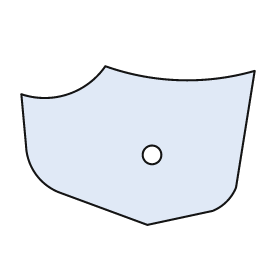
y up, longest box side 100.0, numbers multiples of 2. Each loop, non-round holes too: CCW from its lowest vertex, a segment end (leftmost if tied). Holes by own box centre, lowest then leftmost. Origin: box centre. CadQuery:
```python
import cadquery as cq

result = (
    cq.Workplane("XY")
    .moveTo(4.0, -34.0)
    .lineTo(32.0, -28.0)
    .threePointArc((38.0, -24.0), (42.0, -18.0))
    .lineTo(50.0, 32.0)
    .threePointArc((18.0, 28.0), (-14.0, 34.0))
    .threePointArc((-30.0, 22.0), (-50.0, 22.0))
    .lineTo(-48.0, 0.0)
    .threePointArc((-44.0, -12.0), (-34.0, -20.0))
    .close()
    .moveTo(6.0, -4.0)
    .circle(4.0)
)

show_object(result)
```